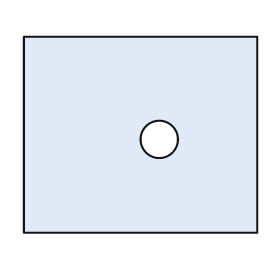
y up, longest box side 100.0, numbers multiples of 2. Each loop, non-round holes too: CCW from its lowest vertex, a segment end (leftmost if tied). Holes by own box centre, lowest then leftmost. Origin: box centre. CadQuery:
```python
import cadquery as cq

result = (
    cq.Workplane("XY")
    .moveTo(-50.0, -42.0)
    .lineTo(50.0, -42.0)
    .lineTo(50.0, 42.0)
    .lineTo(-50.0, 42.0)
    .close()
    .moveTo(8.0, -2.0)
    .circle(8.0)
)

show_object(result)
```